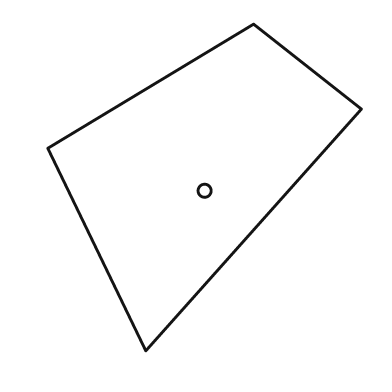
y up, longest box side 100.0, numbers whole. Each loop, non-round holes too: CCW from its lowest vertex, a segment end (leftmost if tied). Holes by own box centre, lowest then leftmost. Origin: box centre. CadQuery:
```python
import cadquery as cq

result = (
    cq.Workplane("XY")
    .moveTo(-18.0, -50.0)
    .lineTo(48.0, 24.0)
    .lineTo(15.0, 50.0)
    .lineTo(-48.0, 12.0)
    .close()
    .moveTo(0.0, -1.0)
    .circle(2.0)
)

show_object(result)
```